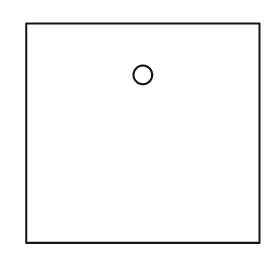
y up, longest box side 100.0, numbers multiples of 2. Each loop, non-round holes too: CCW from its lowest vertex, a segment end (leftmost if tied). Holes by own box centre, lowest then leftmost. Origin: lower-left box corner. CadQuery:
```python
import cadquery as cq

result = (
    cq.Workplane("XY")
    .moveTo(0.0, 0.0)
    .lineTo(100.0, 0.0)
    .lineTo(100.0, 94.0)
    .lineTo(0.0, 94.0)
    .close()
    .moveTo(50.0, 72.0)
    .circle(4.0)
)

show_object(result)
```